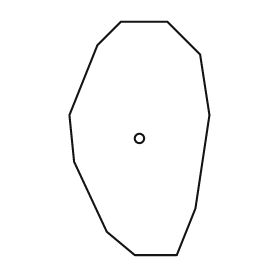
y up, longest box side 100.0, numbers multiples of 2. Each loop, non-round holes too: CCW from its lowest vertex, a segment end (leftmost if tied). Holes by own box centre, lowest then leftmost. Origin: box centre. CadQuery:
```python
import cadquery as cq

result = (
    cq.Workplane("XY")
    .moveTo(-2.0, -50.0)
    .lineTo(16.0, -50.0)
    .lineTo(24.0, -30.0)
    .lineTo(30.0, 10.0)
    .lineTo(26.0, 36.0)
    .lineTo(12.0, 50.0)
    .lineTo(-8.0, 50.0)
    .lineTo(-18.0, 40.0)
    .lineTo(-30.0, 10.0)
    .lineTo(-28.0, -10.0)
    .lineTo(-14.0, -40.0)
    .close()
    .moveTo(0.0, 0.0)
    .circle(2.0)
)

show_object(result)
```